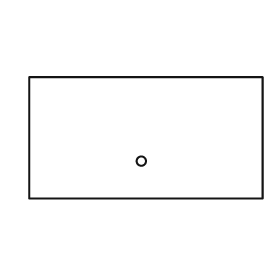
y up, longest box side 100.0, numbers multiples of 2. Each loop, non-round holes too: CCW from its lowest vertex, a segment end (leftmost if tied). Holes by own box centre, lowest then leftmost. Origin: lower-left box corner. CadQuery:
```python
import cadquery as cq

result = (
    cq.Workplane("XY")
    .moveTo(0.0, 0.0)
    .lineTo(100.0, 0.0)
    .lineTo(100.0, 52.0)
    .lineTo(0.0, 52.0)
    .close()
    .moveTo(48.0, 16.0)
    .circle(2.0)
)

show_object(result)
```